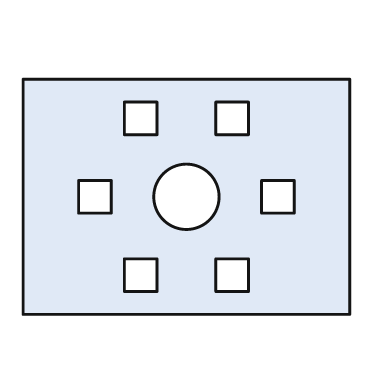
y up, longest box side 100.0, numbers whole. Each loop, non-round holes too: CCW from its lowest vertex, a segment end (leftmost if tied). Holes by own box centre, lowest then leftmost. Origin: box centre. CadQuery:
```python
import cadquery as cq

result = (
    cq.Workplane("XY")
    .moveTo(-50.0, -36.0)
    .lineTo(50.0, -36.0)
    .lineTo(50.0, 36.0)
    .lineTo(-50.0, 36.0)
    .close()
    .moveTo(-19.0, -29.0)
    .lineTo(-9.0, -29.0)
    .lineTo(-9.0, -19.0)
    .lineTo(-19.0, -19.0)
    .close()
    .moveTo(9.0, -29.0)
    .lineTo(19.0, -29.0)
    .lineTo(19.0, -19.0)
    .lineTo(9.0, -19.0)
    .close()
    .moveTo(-33.0, -5.0)
    .lineTo(-23.0, -5.0)
    .lineTo(-23.0, 5.0)
    .lineTo(-33.0, 5.0)
    .close()
    .moveTo(0.0, 0.0)
    .circle(10.0)
    .moveTo(23.0, -5.0)
    .lineTo(33.0, -5.0)
    .lineTo(33.0, 5.0)
    .lineTo(23.0, 5.0)
    .close()
    .moveTo(-19.0, 19.0)
    .lineTo(-9.0, 19.0)
    .lineTo(-9.0, 29.0)
    .lineTo(-19.0, 29.0)
    .close()
    .moveTo(9.0, 19.0)
    .lineTo(19.0, 19.0)
    .lineTo(19.0, 29.0)
    .lineTo(9.0, 29.0)
    .close()
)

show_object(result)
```